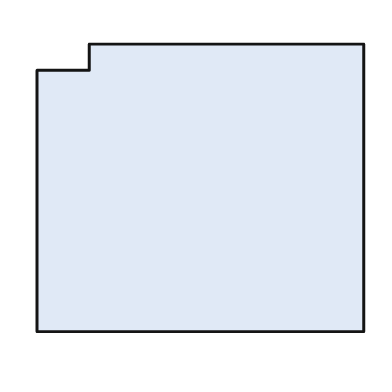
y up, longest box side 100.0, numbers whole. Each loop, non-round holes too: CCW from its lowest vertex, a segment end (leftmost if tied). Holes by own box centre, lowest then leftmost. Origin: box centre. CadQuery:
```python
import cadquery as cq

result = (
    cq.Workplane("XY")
    .moveTo(-50.0, -44.0)
    .lineTo(50.0, -44.0)
    .lineTo(50.0, 44.0)
    .lineTo(-34.0, 44.0)
    .lineTo(-34.0, 36.0)
    .lineTo(-50.0, 36.0)
    .close()
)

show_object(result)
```